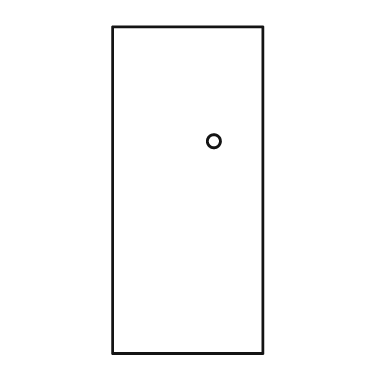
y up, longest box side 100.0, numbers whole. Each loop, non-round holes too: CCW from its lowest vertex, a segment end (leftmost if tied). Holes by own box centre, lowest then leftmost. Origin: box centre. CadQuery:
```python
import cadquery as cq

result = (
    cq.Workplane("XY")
    .moveTo(-23.0, -50.0)
    .lineTo(23.0, -50.0)
    .lineTo(23.0, 50.0)
    .lineTo(-23.0, 50.0)
    .close()
    .moveTo(8.0, 15.0)
    .circle(2.0)
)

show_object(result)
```